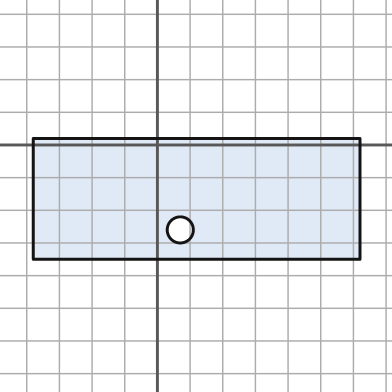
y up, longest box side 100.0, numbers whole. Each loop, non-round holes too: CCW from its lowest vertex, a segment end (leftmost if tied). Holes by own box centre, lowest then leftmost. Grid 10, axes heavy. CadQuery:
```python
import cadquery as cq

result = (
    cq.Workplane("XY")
    .moveTo(-38.0, -35.0)
    .lineTo(62.0, -35.0)
    .lineTo(62.0, 2.0)
    .lineTo(-38.0, 2.0)
    .close()
    .moveTo(7.0, -26.0)
    .circle(4.0)
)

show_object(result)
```